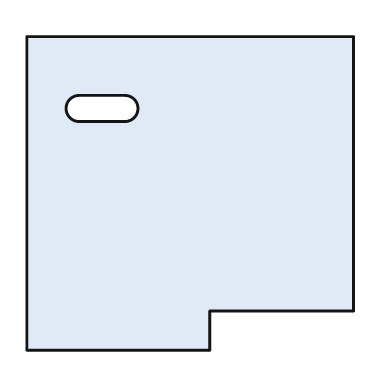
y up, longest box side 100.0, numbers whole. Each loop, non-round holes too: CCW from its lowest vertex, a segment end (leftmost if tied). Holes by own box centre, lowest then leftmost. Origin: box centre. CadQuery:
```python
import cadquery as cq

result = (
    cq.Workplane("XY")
    .moveTo(-50.0, -48.0)
    .lineTo(6.0, -48.0)
    .lineTo(6.0, -36.0)
    .lineTo(50.0, -36.0)
    .lineTo(50.0, 48.0)
    .lineTo(-50.0, 48.0)
    .close()
    .moveTo(-34.0, 22.0)
    .lineTo(-20.0, 22.0)
    .threePointArc((-16.0, 26.0), (-20.0, 30.0))
    .lineTo(-34.0, 30.0)
    .threePointArc((-38.0, 26.0), (-34.0, 22.0))
    .close()
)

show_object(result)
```